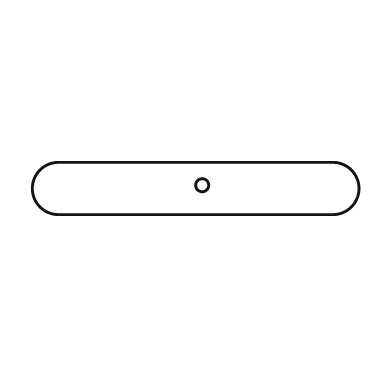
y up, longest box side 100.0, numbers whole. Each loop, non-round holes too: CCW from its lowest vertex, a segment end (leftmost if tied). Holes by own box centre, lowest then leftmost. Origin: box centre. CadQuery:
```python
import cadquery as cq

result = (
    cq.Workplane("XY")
    .moveTo(-42.0, -8.0)
    .lineTo(42.0, -8.0)
    .threePointArc((50.0, 0.0), (42.0, 8.0))
    .lineTo(-42.0, 8.0)
    .threePointArc((-50.0, 0.0), (-42.0, -8.0))
    .close()
    .moveTo(2.0, 1.0)
    .circle(2.0)
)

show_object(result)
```